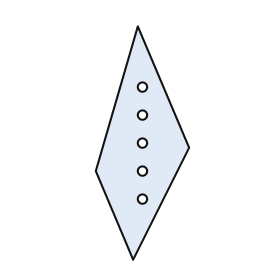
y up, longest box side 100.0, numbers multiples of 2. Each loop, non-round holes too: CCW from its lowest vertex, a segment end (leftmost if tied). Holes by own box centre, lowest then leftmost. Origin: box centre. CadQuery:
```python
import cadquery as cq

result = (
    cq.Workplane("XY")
    .moveTo(-4.0, -50.0)
    .lineTo(20.0, -2.0)
    .lineTo(-2.0, 50.0)
    .lineTo(-20.0, -12.0)
    .close()
    .moveTo(0.0, -24.0)
    .circle(2.0)
    .moveTo(0.0, -12.0)
    .circle(2.0)
    .moveTo(0.0, 0.0)
    .circle(2.0)
    .moveTo(0.0, 12.0)
    .circle(2.0)
    .moveTo(0.0, 24.0)
    .circle(2.0)
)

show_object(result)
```